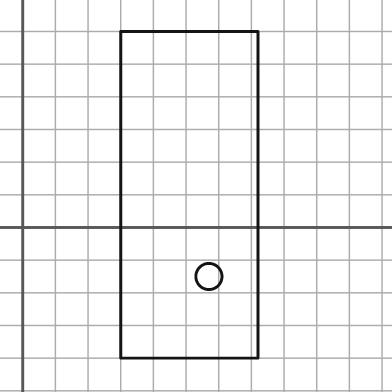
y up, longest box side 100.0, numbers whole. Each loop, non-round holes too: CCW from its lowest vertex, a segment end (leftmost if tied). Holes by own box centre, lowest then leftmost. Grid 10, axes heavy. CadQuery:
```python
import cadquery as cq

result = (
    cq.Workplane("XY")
    .moveTo(30.0, -40.0)
    .lineTo(72.0, -40.0)
    .lineTo(72.0, 60.0)
    .lineTo(30.0, 60.0)
    .close()
    .moveTo(57.0, -15.0)
    .circle(4.0)
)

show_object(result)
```